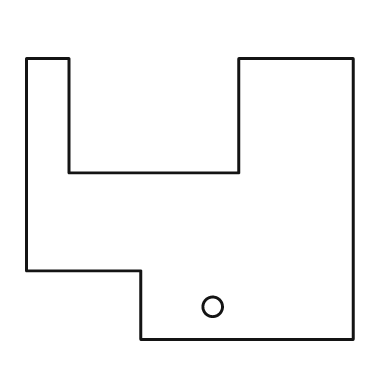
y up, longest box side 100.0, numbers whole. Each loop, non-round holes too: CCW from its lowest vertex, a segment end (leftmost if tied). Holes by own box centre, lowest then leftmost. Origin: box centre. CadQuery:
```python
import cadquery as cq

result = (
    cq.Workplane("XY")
    .moveTo(-15.0, -43.0)
    .lineTo(50.0, -43.0)
    .lineTo(50.0, 43.0)
    .lineTo(15.0, 43.0)
    .lineTo(15.0, 8.0)
    .lineTo(-37.0, 8.0)
    .lineTo(-37.0, 43.0)
    .lineTo(-50.0, 43.0)
    .lineTo(-50.0, -22.0)
    .lineTo(-15.0, -22.0)
    .close()
    .moveTo(7.0, -33.0)
    .circle(3.0)
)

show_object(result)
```